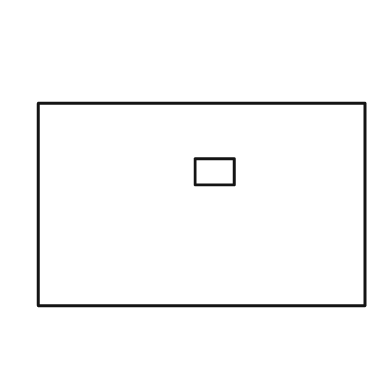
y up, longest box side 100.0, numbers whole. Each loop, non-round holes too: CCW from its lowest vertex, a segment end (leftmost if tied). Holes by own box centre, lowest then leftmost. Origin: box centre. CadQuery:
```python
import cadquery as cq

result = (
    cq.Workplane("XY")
    .moveTo(-50.0, -31.0)
    .lineTo(50.0, -31.0)
    .lineTo(50.0, 31.0)
    .lineTo(-50.0, 31.0)
    .close()
    .moveTo(-2.0, 6.0)
    .lineTo(10.0, 6.0)
    .lineTo(10.0, 14.0)
    .lineTo(-2.0, 14.0)
    .close()
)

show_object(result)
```